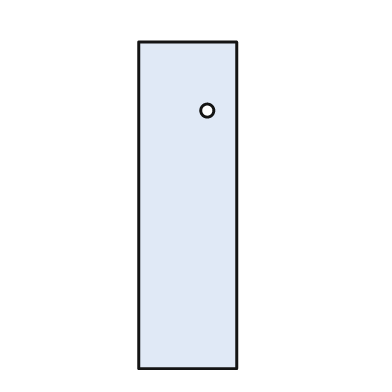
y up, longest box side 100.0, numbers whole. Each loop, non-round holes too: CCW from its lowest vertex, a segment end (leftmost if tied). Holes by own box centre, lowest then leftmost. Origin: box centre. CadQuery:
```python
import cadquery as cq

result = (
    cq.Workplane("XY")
    .moveTo(-15.0, -50.0)
    .lineTo(15.0, -50.0)
    .lineTo(15.0, 50.0)
    .lineTo(-15.0, 50.0)
    .close()
    .moveTo(6.0, 29.0)
    .circle(2.0)
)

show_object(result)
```